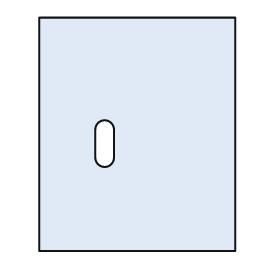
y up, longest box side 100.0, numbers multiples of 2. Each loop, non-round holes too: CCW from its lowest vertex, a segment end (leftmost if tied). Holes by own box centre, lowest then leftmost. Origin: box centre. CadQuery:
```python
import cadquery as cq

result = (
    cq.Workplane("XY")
    .moveTo(-42.0, -50.0)
    .lineTo(42.0, -50.0)
    .lineTo(42.0, 50.0)
    .lineTo(-42.0, 50.0)
    .close()
    .moveTo(-18.0, -10.0)
    .threePointArc((-14.0, -14.0), (-10.0, -10.0))
    .lineTo(-10.0, 2.0)
    .threePointArc((-14.0, 6.0), (-18.0, 2.0))
    .close()
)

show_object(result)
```